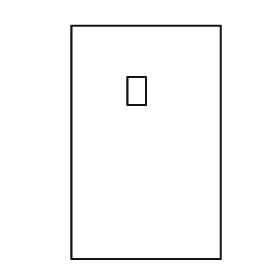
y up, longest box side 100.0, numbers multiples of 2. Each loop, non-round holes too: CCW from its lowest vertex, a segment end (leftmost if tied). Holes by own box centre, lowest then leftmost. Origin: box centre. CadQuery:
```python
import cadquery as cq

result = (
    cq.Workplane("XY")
    .moveTo(-32.0, -50.0)
    .lineTo(32.0, -50.0)
    .lineTo(32.0, 50.0)
    .lineTo(-32.0, 50.0)
    .close()
    .moveTo(-8.0, 16.0)
    .lineTo(0.0, 16.0)
    .lineTo(0.0, 28.0)
    .lineTo(-8.0, 28.0)
    .close()
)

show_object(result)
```